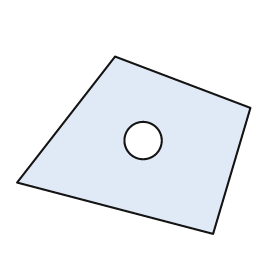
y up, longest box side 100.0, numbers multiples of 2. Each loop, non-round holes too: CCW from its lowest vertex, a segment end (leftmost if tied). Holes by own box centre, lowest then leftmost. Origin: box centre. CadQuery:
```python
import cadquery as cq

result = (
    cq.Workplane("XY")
    .moveTo(34.0, -38.0)
    .lineTo(50.0, 16.0)
    .lineTo(-8.0, 38.0)
    .lineTo(-50.0, -16.0)
    .close()
    .moveTo(4.0, 2.0)
    .circle(8.0)
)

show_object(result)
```